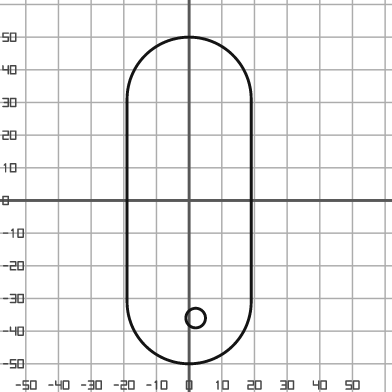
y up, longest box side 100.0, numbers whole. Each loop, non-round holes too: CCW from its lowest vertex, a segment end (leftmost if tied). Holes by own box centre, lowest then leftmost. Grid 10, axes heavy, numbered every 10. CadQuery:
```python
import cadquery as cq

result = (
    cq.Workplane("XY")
    .moveTo(-19.0, -31.0)
    .threePointArc((0.0, -50.0), (19.0, -31.0))
    .lineTo(19.0, 31.0)
    .threePointArc((0.0, 50.0), (-19.0, 31.0))
    .close()
    .moveTo(2.0, -36.0)
    .circle(3.0)
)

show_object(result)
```